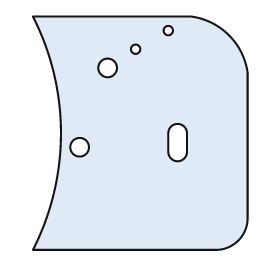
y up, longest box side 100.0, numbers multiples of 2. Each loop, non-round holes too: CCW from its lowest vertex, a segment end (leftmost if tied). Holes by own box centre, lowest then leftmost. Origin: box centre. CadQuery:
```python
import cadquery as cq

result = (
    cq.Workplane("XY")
    .moveTo(-46.0, -50.0)
    .lineTo(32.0, -50.0)
    .threePointArc((42.0, -46.0), (46.0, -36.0))
    .lineTo(46.0, 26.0)
    .threePointArc((38.0, 42.0), (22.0, 50.0))
    .lineTo(-46.0, 50.0)
    .threePointArc((-34.0, 0.0), (-46.0, -50.0))
    .close()
    .moveTo(-26.0, -6.0)
    .circle(4.0)
    .moveTo(12.0, -8.0)
    .threePointArc((16.0, -12.0), (20.0, -8.0))
    .lineTo(20.0, 0.0)
    .threePointArc((16.0, 4.0), (12.0, 0.0))
    .close()
    .moveTo(-14.0, 28.0)
    .circle(4.0)
    .moveTo(-2.0, 36.0)
    .circle(2.0)
    .moveTo(12.0, 44.0)
    .circle(2.0)
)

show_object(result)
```